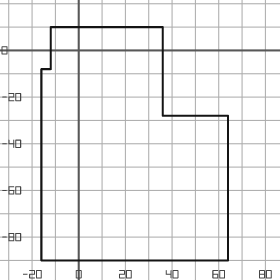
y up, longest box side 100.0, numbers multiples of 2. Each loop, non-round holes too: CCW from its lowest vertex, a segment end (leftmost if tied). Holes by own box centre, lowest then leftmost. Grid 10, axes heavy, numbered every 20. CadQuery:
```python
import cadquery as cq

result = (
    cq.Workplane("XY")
    .moveTo(-16.0, -90.0)
    .lineTo(64.0, -90.0)
    .lineTo(64.0, -28.0)
    .lineTo(36.0, -28.0)
    .lineTo(36.0, 10.0)
    .lineTo(-12.0, 10.0)
    .lineTo(-12.0, -8.0)
    .lineTo(-16.0, -8.0)
    .close()
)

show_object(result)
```